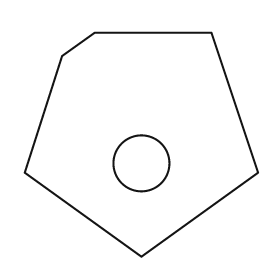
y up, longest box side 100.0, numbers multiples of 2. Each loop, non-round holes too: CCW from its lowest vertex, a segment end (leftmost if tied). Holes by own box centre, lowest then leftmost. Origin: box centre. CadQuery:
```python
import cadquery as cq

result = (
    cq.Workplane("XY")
    .moveTo(0.0, -48.0)
    .lineTo(50.0, -12.0)
    .lineTo(30.0, 48.0)
    .lineTo(-20.0, 48.0)
    .lineTo(-34.0, 38.0)
    .lineTo(-50.0, -12.0)
    .close()
    .moveTo(0.0, -8.0)
    .circle(12.0)
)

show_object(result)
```